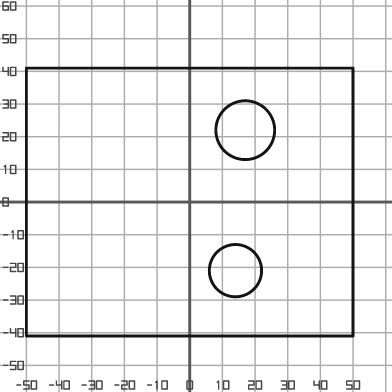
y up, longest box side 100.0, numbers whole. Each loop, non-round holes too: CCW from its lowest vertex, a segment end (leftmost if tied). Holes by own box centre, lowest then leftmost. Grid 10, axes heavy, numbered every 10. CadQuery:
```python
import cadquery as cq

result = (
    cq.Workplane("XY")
    .moveTo(-50.0, -41.0)
    .lineTo(50.0, -41.0)
    .lineTo(50.0, 41.0)
    .lineTo(-50.0, 41.0)
    .close()
    .moveTo(14.0, -21.0)
    .circle(8.0)
    .moveTo(17.0, 22.0)
    .circle(9.0)
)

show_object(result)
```